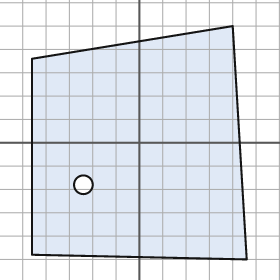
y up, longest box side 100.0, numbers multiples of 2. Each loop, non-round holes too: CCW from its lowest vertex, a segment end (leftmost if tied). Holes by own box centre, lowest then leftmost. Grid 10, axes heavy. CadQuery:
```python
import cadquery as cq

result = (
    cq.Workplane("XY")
    .moveTo(46.0, -50.0)
    .lineTo(40.0, 50.0)
    .lineTo(-46.0, 36.0)
    .lineTo(-46.0, -48.0)
    .close()
    .moveTo(-24.0, -18.0)
    .circle(4.0)
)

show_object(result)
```